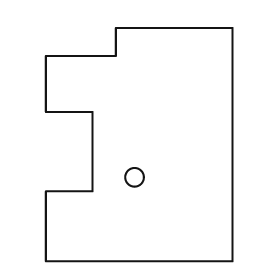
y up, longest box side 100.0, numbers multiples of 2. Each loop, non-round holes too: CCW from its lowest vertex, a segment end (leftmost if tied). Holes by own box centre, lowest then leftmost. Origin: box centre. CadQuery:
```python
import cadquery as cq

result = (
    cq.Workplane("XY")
    .moveTo(-40.0, -50.0)
    .lineTo(40.0, -50.0)
    .lineTo(40.0, 50.0)
    .lineTo(-10.0, 50.0)
    .lineTo(-10.0, 38.0)
    .lineTo(-40.0, 38.0)
    .lineTo(-40.0, 14.0)
    .lineTo(-20.0, 14.0)
    .lineTo(-20.0, -20.0)
    .lineTo(-40.0, -20.0)
    .close()
    .moveTo(-2.0, -14.0)
    .circle(4.0)
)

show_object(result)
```